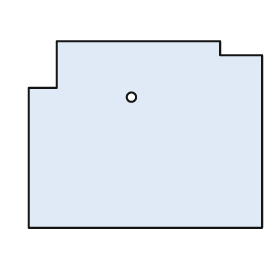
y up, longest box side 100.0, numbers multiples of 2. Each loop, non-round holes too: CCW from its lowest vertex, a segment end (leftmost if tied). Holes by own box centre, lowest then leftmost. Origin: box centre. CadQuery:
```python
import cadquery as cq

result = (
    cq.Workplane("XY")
    .moveTo(-50.0, -40.0)
    .lineTo(50.0, -40.0)
    .lineTo(50.0, 34.0)
    .lineTo(32.0, 34.0)
    .lineTo(32.0, 40.0)
    .lineTo(-38.0, 40.0)
    .lineTo(-38.0, 20.0)
    .lineTo(-50.0, 20.0)
    .close()
    .moveTo(-6.0, 16.0)
    .circle(2.0)
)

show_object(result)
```